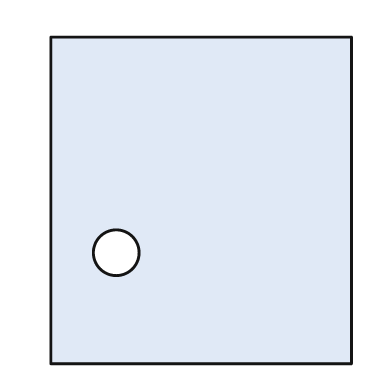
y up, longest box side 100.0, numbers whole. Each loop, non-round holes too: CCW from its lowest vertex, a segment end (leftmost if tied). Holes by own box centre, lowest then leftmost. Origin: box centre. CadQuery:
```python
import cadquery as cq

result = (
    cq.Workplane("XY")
    .moveTo(-46.0, -50.0)
    .lineTo(46.0, -50.0)
    .lineTo(46.0, 50.0)
    .lineTo(-46.0, 50.0)
    .close()
    .moveTo(-26.0, -16.0)
    .circle(7.0)
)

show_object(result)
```